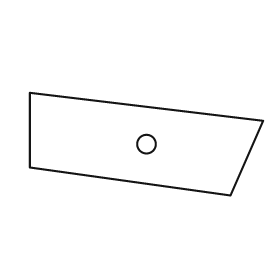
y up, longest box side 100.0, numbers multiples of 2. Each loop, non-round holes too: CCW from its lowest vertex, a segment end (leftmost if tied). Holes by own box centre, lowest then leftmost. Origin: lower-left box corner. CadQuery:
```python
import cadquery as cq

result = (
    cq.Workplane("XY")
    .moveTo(86.0, 0.0)
    .lineTo(100.0, 32.0)
    .lineTo(0.0, 44.0)
    .lineTo(0.0, 12.0)
    .close()
    .moveTo(50.0, 22.0)
    .circle(4.0)
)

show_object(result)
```